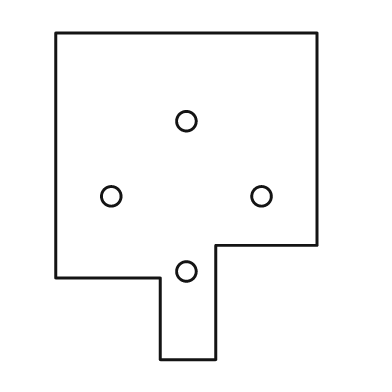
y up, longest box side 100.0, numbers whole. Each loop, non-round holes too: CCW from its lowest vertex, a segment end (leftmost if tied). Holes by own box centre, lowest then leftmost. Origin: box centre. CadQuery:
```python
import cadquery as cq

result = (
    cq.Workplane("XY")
    .moveTo(-8.0, -50.0)
    .lineTo(9.0, -50.0)
    .lineTo(9.0, -15.0)
    .lineTo(40.0, -15.0)
    .lineTo(40.0, 50.0)
    .lineTo(-40.0, 50.0)
    .lineTo(-40.0, -25.0)
    .lineTo(-8.0, -25.0)
    .close()
    .moveTo(0.0, -23.0)
    .circle(3.0)
    .moveTo(-23.0, 0.0)
    .circle(3.0)
    .moveTo(23.0, 0.0)
    .circle(3.0)
    .moveTo(0.0, 23.0)
    .circle(3.0)
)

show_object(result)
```